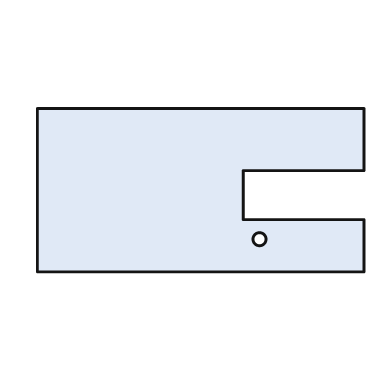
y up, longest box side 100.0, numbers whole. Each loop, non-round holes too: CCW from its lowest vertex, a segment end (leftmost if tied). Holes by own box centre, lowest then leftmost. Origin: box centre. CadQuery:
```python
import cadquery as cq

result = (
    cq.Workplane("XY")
    .moveTo(-50.0, -25.0)
    .lineTo(50.0, -25.0)
    .lineTo(50.0, -9.0)
    .lineTo(13.0, -9.0)
    .lineTo(13.0, 6.0)
    .lineTo(50.0, 6.0)
    .lineTo(50.0, 25.0)
    .lineTo(-50.0, 25.0)
    .close()
    .moveTo(18.0, -15.0)
    .circle(2.0)
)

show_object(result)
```